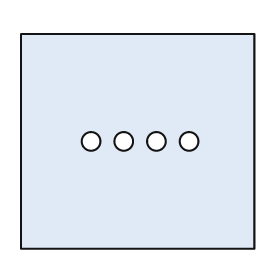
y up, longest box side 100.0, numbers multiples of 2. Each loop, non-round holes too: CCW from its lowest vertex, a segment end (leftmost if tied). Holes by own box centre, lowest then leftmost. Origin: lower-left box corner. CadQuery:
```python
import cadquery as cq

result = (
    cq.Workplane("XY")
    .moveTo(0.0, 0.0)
    .lineTo(100.0, 0.0)
    .lineTo(100.0, 92.0)
    .lineTo(0.0, 92.0)
    .close()
    .moveTo(30.0, 46.0)
    .circle(4.0)
    .moveTo(44.0, 46.0)
    .circle(4.0)
    .moveTo(58.0, 46.0)
    .circle(4.0)
    .moveTo(72.0, 46.0)
    .circle(4.0)
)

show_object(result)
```